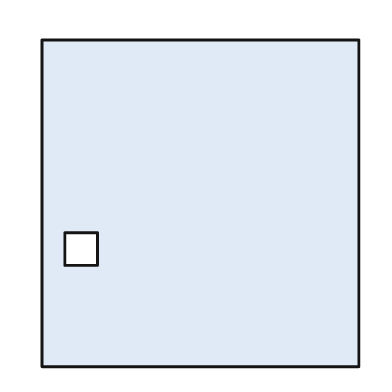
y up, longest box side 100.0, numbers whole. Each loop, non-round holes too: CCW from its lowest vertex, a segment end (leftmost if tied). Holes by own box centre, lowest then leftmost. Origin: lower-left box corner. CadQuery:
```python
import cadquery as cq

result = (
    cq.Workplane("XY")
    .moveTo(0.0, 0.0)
    .lineTo(97.0, 0.0)
    .lineTo(97.0, 100.0)
    .lineTo(0.0, 100.0)
    .close()
    .moveTo(7.0, 31.0)
    .lineTo(17.0, 31.0)
    .lineTo(17.0, 41.0)
    .lineTo(7.0, 41.0)
    .close()
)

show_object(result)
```